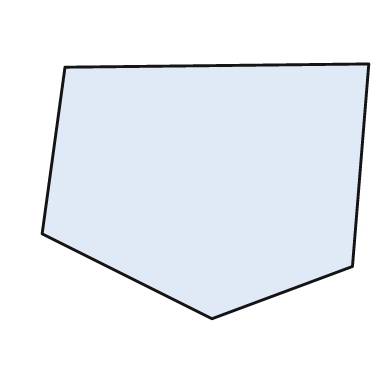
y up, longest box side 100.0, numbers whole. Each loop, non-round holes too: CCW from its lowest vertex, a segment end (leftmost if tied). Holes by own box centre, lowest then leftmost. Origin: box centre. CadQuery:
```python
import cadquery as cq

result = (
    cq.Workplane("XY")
    .moveTo(2.0, -39.0)
    .lineTo(45.0, -23.0)
    .lineTo(50.0, 39.0)
    .lineTo(-43.0, 38.0)
    .lineTo(-50.0, -13.0)
    .close()
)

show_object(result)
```